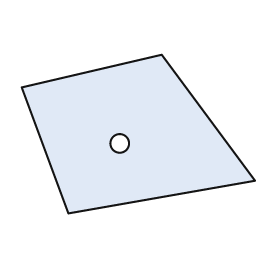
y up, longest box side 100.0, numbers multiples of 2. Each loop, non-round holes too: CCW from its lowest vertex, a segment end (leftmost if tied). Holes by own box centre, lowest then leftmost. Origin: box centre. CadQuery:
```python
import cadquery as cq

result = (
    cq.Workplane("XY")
    .moveTo(-30.0, -34.0)
    .lineTo(50.0, -20.0)
    .lineTo(10.0, 34.0)
    .lineTo(-50.0, 20.0)
    .close()
    .moveTo(-8.0, -4.0)
    .circle(4.0)
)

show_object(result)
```